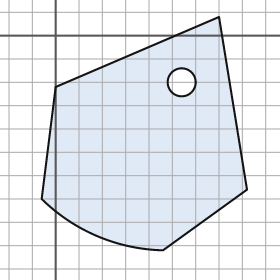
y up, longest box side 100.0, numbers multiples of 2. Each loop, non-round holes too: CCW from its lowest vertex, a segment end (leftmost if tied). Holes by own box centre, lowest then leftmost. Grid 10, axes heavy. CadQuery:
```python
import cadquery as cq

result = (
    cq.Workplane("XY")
    .moveTo(46.0, -92.0)
    .lineTo(82.0, -66.0)
    .lineTo(70.0, 8.0)
    .lineTo(0.0, -22.0)
    .lineTo(-6.0, -70.0)
    .threePointArc((18.0, -86.0), (46.0, -92.0))
    .close()
    .moveTo(54.0, -20.0)
    .circle(6.0)
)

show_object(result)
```